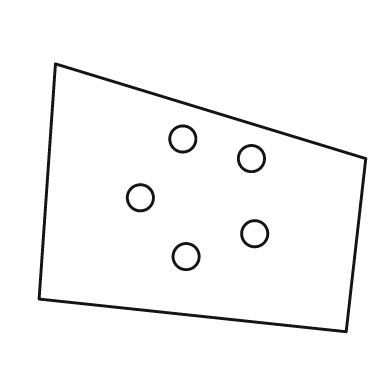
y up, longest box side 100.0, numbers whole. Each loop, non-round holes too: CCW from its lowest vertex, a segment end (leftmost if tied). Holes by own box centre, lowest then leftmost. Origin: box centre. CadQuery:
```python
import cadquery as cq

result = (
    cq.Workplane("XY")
    .moveTo(44.0, -41.0)
    .lineTo(50.0, 12.0)
    .lineTo(-45.0, 41.0)
    .lineTo(-50.0, -31.0)
    .close()
    .moveTo(-5.0, -18.0)
    .circle(4.0)
    .moveTo(16.0, -11.0)
    .circle(4.0)
    .moveTo(-19.0, 0.0)
    .circle(4.0)
    .moveTo(15.0, 12.0)
    .circle(4.0)
    .moveTo(-6.0, 18.0)
    .circle(4.0)
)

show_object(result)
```